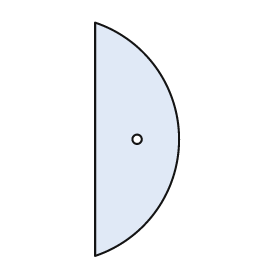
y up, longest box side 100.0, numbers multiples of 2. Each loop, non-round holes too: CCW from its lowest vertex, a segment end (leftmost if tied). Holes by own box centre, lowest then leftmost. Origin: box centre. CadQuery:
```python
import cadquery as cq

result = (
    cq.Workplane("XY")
    .moveTo(-18.0, -50.0)
    .threePointArc((18.0, 0.0), (-18.0, 50.0))
    .close()
    .moveTo(0.0, 0.0)
    .circle(2.0)
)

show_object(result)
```